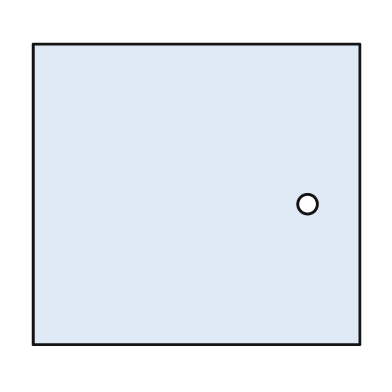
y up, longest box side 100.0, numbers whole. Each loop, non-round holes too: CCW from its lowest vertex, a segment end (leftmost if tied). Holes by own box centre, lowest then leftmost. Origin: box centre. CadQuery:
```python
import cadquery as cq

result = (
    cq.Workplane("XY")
    .moveTo(-50.0, -46.0)
    .lineTo(50.0, -46.0)
    .lineTo(50.0, 46.0)
    .lineTo(-50.0, 46.0)
    .close()
    .moveTo(34.0, -3.0)
    .circle(3.0)
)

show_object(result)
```